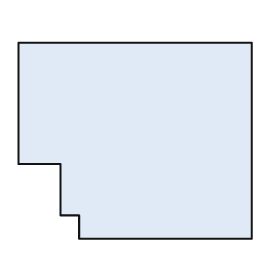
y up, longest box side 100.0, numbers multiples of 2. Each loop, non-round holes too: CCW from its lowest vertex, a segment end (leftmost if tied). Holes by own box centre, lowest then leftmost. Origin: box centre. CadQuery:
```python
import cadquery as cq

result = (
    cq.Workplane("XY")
    .moveTo(-24.0, -42.0)
    .lineTo(50.0, -42.0)
    .lineTo(50.0, 42.0)
    .lineTo(-50.0, 42.0)
    .lineTo(-50.0, -10.0)
    .lineTo(-32.0, -10.0)
    .lineTo(-32.0, -32.0)
    .lineTo(-24.0, -32.0)
    .close()
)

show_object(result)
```